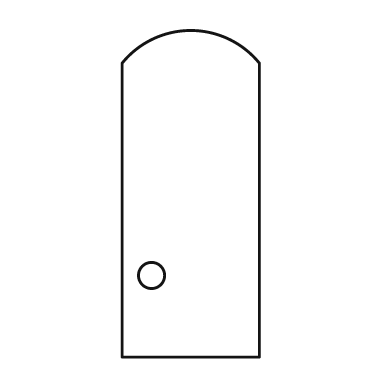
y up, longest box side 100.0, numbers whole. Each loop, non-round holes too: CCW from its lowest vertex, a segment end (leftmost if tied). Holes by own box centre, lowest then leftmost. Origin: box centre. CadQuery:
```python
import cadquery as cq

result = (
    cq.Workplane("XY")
    .moveTo(-21.0, -50.0)
    .lineTo(21.0, -50.0)
    .lineTo(21.0, 40.0)
    .threePointArc((0.0, 50.0), (-21.0, 40.0))
    .close()
    .moveTo(-12.0, -25.0)
    .circle(4.0)
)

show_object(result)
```